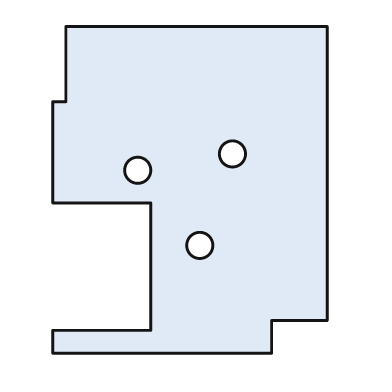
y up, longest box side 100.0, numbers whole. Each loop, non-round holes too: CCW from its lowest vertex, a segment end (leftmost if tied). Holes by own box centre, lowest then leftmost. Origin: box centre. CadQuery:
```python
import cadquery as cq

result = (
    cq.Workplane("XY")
    .moveTo(-42.0, -50.0)
    .lineTo(25.0, -50.0)
    .lineTo(25.0, -40.0)
    .lineTo(42.0, -40.0)
    .lineTo(42.0, 50.0)
    .lineTo(-38.0, 50.0)
    .lineTo(-38.0, 27.0)
    .lineTo(-42.0, 27.0)
    .lineTo(-42.0, -4.0)
    .lineTo(-12.0, -4.0)
    .lineTo(-12.0, -43.0)
    .lineTo(-42.0, -43.0)
    .close()
    .moveTo(3.0, -17.0)
    .circle(4.0)
    .moveTo(-16.0, 6.0)
    .circle(4.0)
    .moveTo(13.0, 11.0)
    .circle(4.0)
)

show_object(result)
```